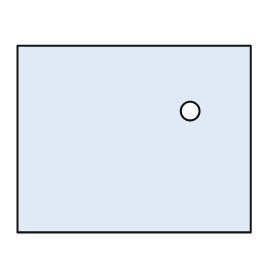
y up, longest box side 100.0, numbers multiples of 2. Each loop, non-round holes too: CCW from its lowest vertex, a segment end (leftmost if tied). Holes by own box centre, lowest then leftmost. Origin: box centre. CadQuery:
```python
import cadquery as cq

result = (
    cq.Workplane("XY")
    .moveTo(-50.0, -40.0)
    .lineTo(50.0, -40.0)
    .lineTo(50.0, 40.0)
    .lineTo(-50.0, 40.0)
    .close()
    .moveTo(24.0, 12.0)
    .circle(4.0)
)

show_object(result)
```